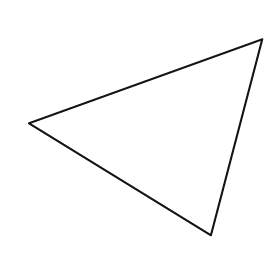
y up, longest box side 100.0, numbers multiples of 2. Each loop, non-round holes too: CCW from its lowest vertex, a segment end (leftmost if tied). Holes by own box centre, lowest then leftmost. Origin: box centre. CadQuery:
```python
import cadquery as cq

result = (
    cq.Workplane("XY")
    .moveTo(28.0, -42.0)
    .lineTo(50.0, 42.0)
    .lineTo(-50.0, 6.0)
    .close()
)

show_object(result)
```